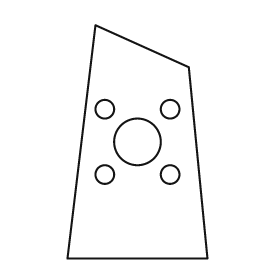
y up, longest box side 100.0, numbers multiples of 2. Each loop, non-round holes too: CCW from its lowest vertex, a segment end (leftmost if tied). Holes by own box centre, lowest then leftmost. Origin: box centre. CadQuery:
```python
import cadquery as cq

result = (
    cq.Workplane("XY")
    .moveTo(-30.0, -50.0)
    .lineTo(30.0, -50.0)
    .lineTo(22.0, 32.0)
    .lineTo(-18.0, 50.0)
    .close()
    .moveTo(-14.0, -14.0)
    .circle(4.0)
    .moveTo(14.0, -14.0)
    .circle(4.0)
    .moveTo(0.0, 0.0)
    .circle(10.0)
    .moveTo(-14.0, 14.0)
    .circle(4.0)
    .moveTo(14.0, 14.0)
    .circle(4.0)
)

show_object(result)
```